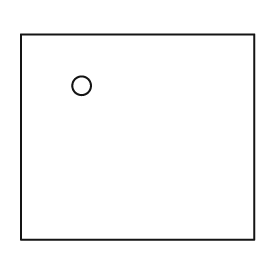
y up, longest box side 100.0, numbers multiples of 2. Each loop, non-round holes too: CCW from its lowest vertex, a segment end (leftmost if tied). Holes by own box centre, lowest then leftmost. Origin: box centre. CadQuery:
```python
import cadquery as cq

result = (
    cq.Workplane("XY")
    .moveTo(-50.0, -44.0)
    .lineTo(50.0, -44.0)
    .lineTo(50.0, 44.0)
    .lineTo(-50.0, 44.0)
    .close()
    .moveTo(-24.0, 22.0)
    .circle(4.0)
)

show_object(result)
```